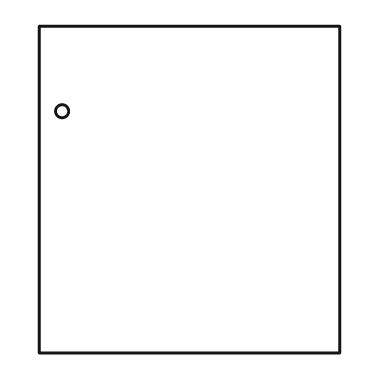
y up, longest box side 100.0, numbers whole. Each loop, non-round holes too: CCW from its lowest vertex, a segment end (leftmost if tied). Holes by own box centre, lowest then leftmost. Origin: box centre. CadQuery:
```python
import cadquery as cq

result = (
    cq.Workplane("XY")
    .moveTo(-46.0, -50.0)
    .lineTo(46.0, -50.0)
    .lineTo(46.0, 50.0)
    .lineTo(-46.0, 50.0)
    .close()
    .moveTo(-39.0, 24.0)
    .circle(2.0)
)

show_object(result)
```